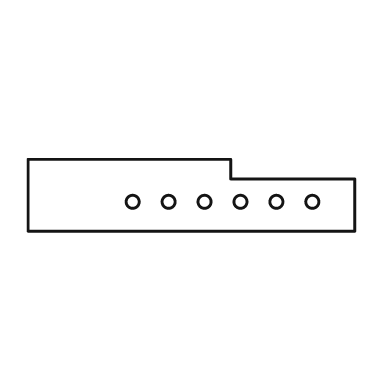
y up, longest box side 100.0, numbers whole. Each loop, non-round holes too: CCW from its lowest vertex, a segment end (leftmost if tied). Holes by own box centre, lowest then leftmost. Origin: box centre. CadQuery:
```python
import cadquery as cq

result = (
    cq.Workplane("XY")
    .moveTo(-50.0, -11.0)
    .lineTo(50.0, -11.0)
    .lineTo(50.0, 5.0)
    .lineTo(12.0, 5.0)
    .lineTo(12.0, 11.0)
    .lineTo(-50.0, 11.0)
    .close()
    .moveTo(-18.0, -2.0)
    .circle(2.0)
    .moveTo(-7.0, -2.0)
    .circle(2.0)
    .moveTo(4.0, -2.0)
    .circle(2.0)
    .moveTo(15.0, -2.0)
    .circle(2.0)
    .moveTo(26.0, -2.0)
    .circle(2.0)
    .moveTo(37.0, -2.0)
    .circle(2.0)
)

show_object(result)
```